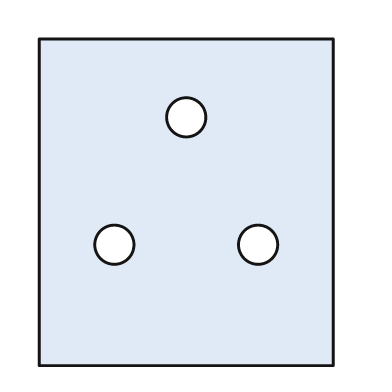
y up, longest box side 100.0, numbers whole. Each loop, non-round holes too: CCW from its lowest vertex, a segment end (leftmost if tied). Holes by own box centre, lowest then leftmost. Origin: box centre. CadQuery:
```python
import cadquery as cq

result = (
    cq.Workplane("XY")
    .moveTo(-45.0, -50.0)
    .lineTo(45.0, -50.0)
    .lineTo(45.0, 50.0)
    .lineTo(-45.0, 50.0)
    .close()
    .moveTo(-22.0, -13.0)
    .circle(6.0)
    .moveTo(22.0, -13.0)
    .circle(6.0)
    .moveTo(0.0, 26.0)
    .circle(6.0)
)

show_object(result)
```